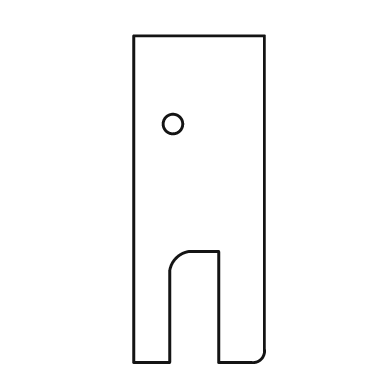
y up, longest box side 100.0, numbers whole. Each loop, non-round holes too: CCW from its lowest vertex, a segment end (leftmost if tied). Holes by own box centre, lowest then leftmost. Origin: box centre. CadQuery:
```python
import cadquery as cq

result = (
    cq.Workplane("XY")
    .moveTo(-20.0, -50.0)
    .lineTo(-9.0, -50.0)
    .lineTo(-9.0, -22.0)
    .threePointArc((-7.0, -18.0), (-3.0, -16.0))
    .lineTo(6.0, -16.0)
    .lineTo(6.0, -50.0)
    .lineTo(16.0, -50.0)
    .threePointArc((19.0, -49.0), (20.0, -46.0))
    .lineTo(20.0, 50.0)
    .lineTo(-20.0, 50.0)
    .close()
    .moveTo(-8.0, 23.0)
    .circle(3.0)
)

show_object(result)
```